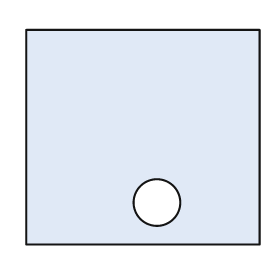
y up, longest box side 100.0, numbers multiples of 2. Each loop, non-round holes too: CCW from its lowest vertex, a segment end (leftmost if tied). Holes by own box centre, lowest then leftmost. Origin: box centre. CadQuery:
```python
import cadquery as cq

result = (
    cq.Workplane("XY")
    .moveTo(-50.0, -46.0)
    .lineTo(50.0, -46.0)
    .lineTo(50.0, 46.0)
    .lineTo(-50.0, 46.0)
    .close()
    .moveTo(6.0, -28.0)
    .circle(10.0)
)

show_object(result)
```